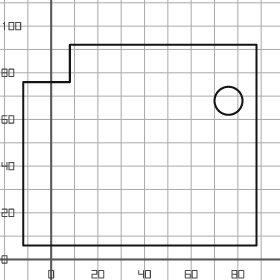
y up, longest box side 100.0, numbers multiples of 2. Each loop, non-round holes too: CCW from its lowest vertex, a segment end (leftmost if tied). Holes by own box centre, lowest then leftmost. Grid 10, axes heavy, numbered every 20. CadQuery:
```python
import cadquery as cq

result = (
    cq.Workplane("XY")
    .moveTo(-12.0, 6.0)
    .lineTo(88.0, 6.0)
    .lineTo(88.0, 92.0)
    .lineTo(8.0, 92.0)
    .lineTo(8.0, 76.0)
    .lineTo(-12.0, 76.0)
    .close()
    .moveTo(76.0, 68.0)
    .circle(6.0)
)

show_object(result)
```